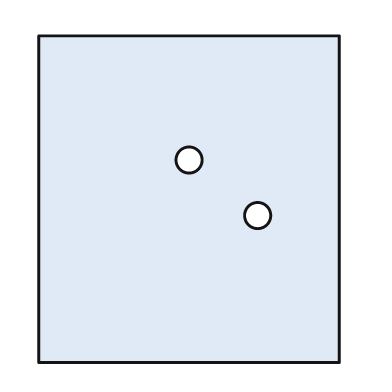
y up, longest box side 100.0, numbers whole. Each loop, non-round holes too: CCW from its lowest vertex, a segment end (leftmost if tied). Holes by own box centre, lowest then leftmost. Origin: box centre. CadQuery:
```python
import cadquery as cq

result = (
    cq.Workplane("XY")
    .moveTo(-46.0, -50.0)
    .lineTo(46.0, -50.0)
    .lineTo(46.0, 50.0)
    .lineTo(-46.0, 50.0)
    .close()
    .moveTo(21.0, -5.0)
    .circle(4.0)
    .moveTo(0.0, 12.0)
    .circle(4.0)
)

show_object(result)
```